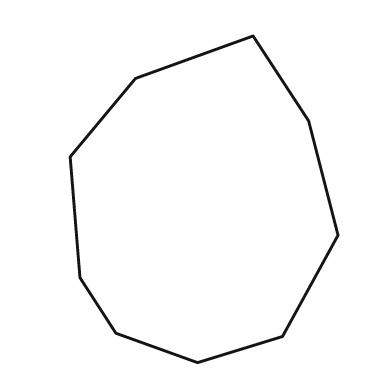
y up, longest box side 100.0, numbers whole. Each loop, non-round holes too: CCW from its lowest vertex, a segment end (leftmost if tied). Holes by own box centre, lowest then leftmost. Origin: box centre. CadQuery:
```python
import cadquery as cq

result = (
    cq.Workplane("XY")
    .moveTo(-2.0, -50.0)
    .lineTo(24.0, -42.0)
    .lineTo(41.0, -11.0)
    .lineTo(32.0, 24.0)
    .lineTo(15.0, 50.0)
    .lineTo(-21.0, 37.0)
    .lineTo(-41.0, 13.0)
    .lineTo(-38.0, -24.0)
    .lineTo(-27.0, -41.0)
    .close()
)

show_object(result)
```